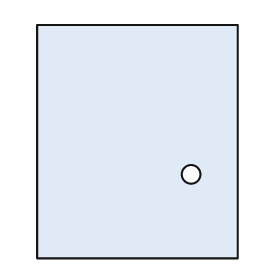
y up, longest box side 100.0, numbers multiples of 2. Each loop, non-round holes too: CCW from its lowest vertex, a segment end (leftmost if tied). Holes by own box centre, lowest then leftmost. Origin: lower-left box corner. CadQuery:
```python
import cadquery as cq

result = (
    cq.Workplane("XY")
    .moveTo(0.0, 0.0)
    .lineTo(86.0, 0.0)
    .lineTo(86.0, 100.0)
    .lineTo(0.0, 100.0)
    .close()
    .moveTo(66.0, 36.0)
    .circle(4.0)
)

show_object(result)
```